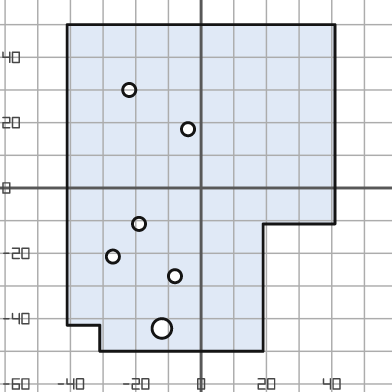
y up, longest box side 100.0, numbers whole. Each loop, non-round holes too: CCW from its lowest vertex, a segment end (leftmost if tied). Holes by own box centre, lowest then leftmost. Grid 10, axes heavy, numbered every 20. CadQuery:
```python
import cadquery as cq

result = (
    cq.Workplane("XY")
    .moveTo(-31.0, -50.0)
    .lineTo(19.0, -50.0)
    .lineTo(19.0, -11.0)
    .lineTo(41.0, -11.0)
    .lineTo(41.0, 50.0)
    .lineTo(-41.0, 50.0)
    .lineTo(-41.0, -42.0)
    .lineTo(-31.0, -42.0)
    .close()
    .moveTo(-12.0, -43.0)
    .circle(3.0)
    .moveTo(-8.0, -27.0)
    .circle(2.0)
    .moveTo(-27.0, -21.0)
    .circle(2.0)
    .moveTo(-19.0, -11.0)
    .circle(2.0)
    .moveTo(-4.0, 18.0)
    .circle(2.0)
    .moveTo(-22.0, 30.0)
    .circle(2.0)
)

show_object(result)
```